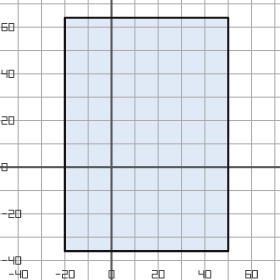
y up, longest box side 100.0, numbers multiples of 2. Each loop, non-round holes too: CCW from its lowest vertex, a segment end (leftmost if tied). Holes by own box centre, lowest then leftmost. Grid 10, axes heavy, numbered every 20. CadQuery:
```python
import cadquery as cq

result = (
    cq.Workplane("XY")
    .moveTo(-20.0, -36.0)
    .lineTo(50.0, -36.0)
    .lineTo(50.0, 64.0)
    .lineTo(-20.0, 64.0)
    .close()
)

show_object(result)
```